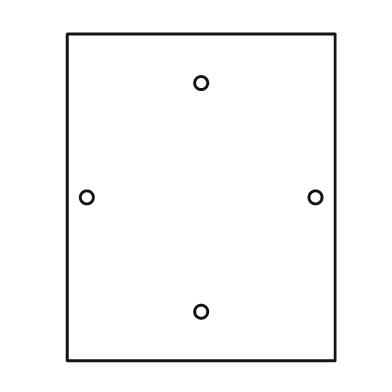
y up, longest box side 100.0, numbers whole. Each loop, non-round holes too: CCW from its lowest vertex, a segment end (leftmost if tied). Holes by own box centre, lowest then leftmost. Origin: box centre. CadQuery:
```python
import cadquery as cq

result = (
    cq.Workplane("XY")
    .moveTo(-41.0, -50.0)
    .lineTo(41.0, -50.0)
    .lineTo(41.0, 50.0)
    .lineTo(-41.0, 50.0)
    .close()
    .moveTo(0.0, -35.0)
    .circle(2.0)
    .moveTo(-35.0, 0.0)
    .circle(2.0)
    .moveTo(35.0, 0.0)
    .circle(2.0)
    .moveTo(0.0, 35.0)
    .circle(2.0)
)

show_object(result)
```